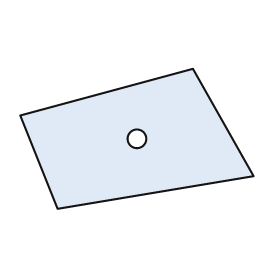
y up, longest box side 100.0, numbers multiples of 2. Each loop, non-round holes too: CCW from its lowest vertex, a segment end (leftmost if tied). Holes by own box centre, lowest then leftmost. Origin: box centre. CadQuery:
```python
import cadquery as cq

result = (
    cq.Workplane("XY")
    .moveTo(-34.0, -30.0)
    .lineTo(50.0, -16.0)
    .lineTo(24.0, 30.0)
    .lineTo(-50.0, 10.0)
    .close()
    .moveTo(0.0, 0.0)
    .circle(4.0)
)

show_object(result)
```